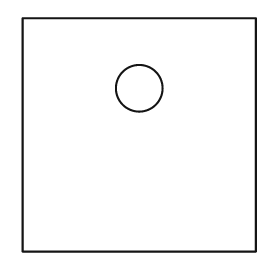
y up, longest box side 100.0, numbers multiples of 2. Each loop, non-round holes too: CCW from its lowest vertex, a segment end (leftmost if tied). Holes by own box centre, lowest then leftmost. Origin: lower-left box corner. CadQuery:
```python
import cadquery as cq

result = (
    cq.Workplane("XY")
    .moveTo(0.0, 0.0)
    .lineTo(100.0, 0.0)
    .lineTo(100.0, 100.0)
    .lineTo(0.0, 100.0)
    .close()
    .moveTo(50.0, 70.0)
    .circle(10.0)
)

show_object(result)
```